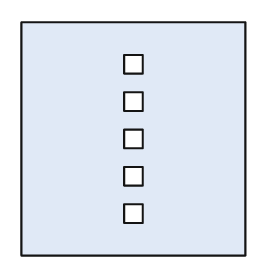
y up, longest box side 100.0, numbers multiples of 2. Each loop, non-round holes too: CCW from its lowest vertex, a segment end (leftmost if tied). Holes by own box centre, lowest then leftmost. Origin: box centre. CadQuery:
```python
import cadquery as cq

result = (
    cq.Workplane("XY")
    .moveTo(-48.0, -50.0)
    .lineTo(48.0, -50.0)
    .lineTo(48.0, 50.0)
    .lineTo(-48.0, 50.0)
    .close()
    .moveTo(-4.0, -36.0)
    .lineTo(4.0, -36.0)
    .lineTo(4.0, -28.0)
    .lineTo(-4.0, -28.0)
    .close()
    .moveTo(-4.0, -20.0)
    .lineTo(4.0, -20.0)
    .lineTo(4.0, -12.0)
    .lineTo(-4.0, -12.0)
    .close()
    .moveTo(-4.0, -4.0)
    .lineTo(4.0, -4.0)
    .lineTo(4.0, 4.0)
    .lineTo(-4.0, 4.0)
    .close()
    .moveTo(-4.0, 12.0)
    .lineTo(4.0, 12.0)
    .lineTo(4.0, 20.0)
    .lineTo(-4.0, 20.0)
    .close()
    .moveTo(-4.0, 28.0)
    .lineTo(4.0, 28.0)
    .lineTo(4.0, 36.0)
    .lineTo(-4.0, 36.0)
    .close()
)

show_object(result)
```